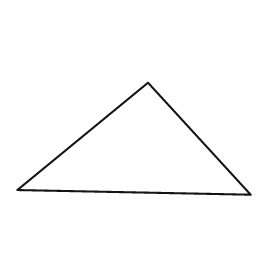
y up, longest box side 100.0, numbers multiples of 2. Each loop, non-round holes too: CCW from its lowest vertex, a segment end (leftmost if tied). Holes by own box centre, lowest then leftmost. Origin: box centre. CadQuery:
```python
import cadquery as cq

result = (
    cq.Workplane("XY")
    .moveTo(50.0, -24.0)
    .lineTo(6.0, 24.0)
    .lineTo(-50.0, -22.0)
    .close()
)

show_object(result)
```